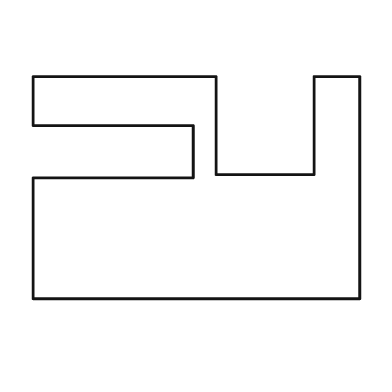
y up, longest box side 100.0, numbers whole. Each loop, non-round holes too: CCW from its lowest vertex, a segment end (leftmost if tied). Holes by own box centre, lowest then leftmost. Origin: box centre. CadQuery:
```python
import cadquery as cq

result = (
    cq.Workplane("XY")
    .moveTo(-50.0, -34.0)
    .lineTo(50.0, -34.0)
    .lineTo(50.0, 34.0)
    .lineTo(36.0, 34.0)
    .lineTo(36.0, 4.0)
    .lineTo(6.0, 4.0)
    .lineTo(6.0, 34.0)
    .lineTo(-50.0, 34.0)
    .lineTo(-50.0, 19.0)
    .lineTo(-1.0, 19.0)
    .lineTo(-1.0, 3.0)
    .lineTo(-50.0, 3.0)
    .close()
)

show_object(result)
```